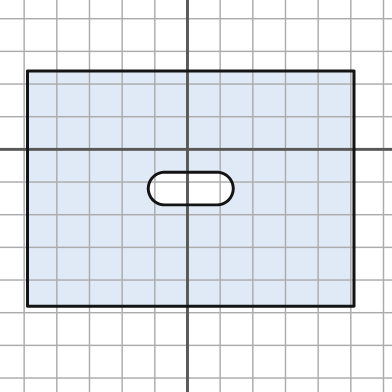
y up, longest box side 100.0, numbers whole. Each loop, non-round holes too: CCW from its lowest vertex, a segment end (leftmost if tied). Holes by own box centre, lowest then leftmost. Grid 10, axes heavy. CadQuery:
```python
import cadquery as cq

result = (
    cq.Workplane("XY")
    .moveTo(-49.0, -48.0)
    .lineTo(51.0, -48.0)
    .lineTo(51.0, 24.0)
    .lineTo(-49.0, 24.0)
    .close()
    .moveTo(-7.0, -17.0)
    .lineTo(9.0, -17.0)
    .threePointArc((14.0, -12.0), (9.0, -7.0))
    .lineTo(-7.0, -7.0)
    .threePointArc((-12.0, -12.0), (-7.0, -17.0))
    .close()
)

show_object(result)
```